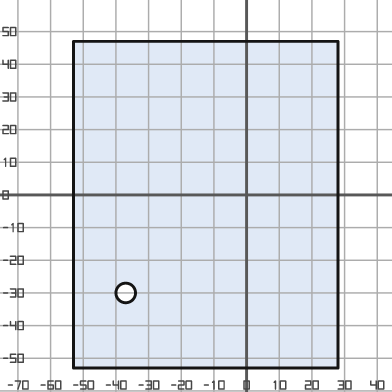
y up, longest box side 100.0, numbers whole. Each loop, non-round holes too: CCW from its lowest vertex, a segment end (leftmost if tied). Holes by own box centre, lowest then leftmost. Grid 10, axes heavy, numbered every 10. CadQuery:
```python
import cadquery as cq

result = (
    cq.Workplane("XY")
    .moveTo(-53.0, -53.0)
    .lineTo(28.0, -53.0)
    .lineTo(28.0, 47.0)
    .lineTo(-53.0, 47.0)
    .close()
    .moveTo(-37.0, -30.0)
    .circle(3.0)
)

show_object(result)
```